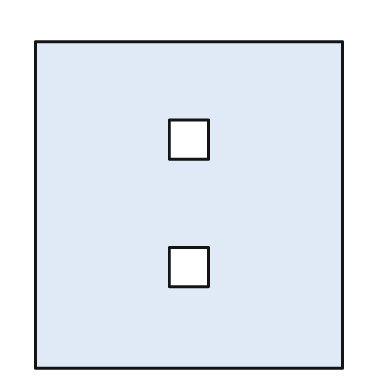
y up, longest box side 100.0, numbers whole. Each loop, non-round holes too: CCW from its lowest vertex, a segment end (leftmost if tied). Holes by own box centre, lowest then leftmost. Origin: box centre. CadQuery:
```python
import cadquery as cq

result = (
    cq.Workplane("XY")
    .moveTo(-47.0, -50.0)
    .lineTo(47.0, -50.0)
    .lineTo(47.0, 50.0)
    .lineTo(-47.0, 50.0)
    .close()
    .moveTo(-6.0, -25.0)
    .lineTo(6.0, -25.0)
    .lineTo(6.0, -13.0)
    .lineTo(-6.0, -13.0)
    .close()
    .moveTo(-6.0, 14.0)
    .lineTo(6.0, 14.0)
    .lineTo(6.0, 26.0)
    .lineTo(-6.0, 26.0)
    .close()
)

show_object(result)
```